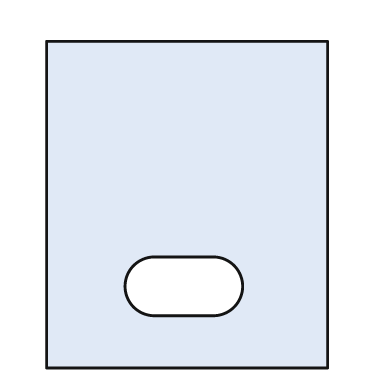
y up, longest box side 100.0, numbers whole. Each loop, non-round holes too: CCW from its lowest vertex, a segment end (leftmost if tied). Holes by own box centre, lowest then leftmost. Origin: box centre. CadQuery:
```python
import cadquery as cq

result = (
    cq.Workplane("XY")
    .moveTo(-43.0, -50.0)
    .lineTo(43.0, -50.0)
    .lineTo(43.0, 50.0)
    .lineTo(-43.0, 50.0)
    .close()
    .moveTo(-10.0, -34.0)
    .lineTo(8.0, -34.0)
    .threePointArc((17.0, -25.0), (8.0, -16.0))
    .lineTo(-10.0, -16.0)
    .threePointArc((-19.0, -25.0), (-10.0, -34.0))
    .close()
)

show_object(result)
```